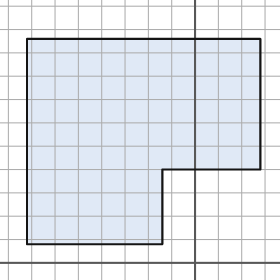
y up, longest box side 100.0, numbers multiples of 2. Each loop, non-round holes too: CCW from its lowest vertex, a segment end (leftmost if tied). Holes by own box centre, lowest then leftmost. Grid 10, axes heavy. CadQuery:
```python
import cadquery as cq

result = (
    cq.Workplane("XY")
    .moveTo(-72.0, 8.0)
    .lineTo(-14.0, 8.0)
    .lineTo(-14.0, 40.0)
    .lineTo(28.0, 40.0)
    .lineTo(28.0, 96.0)
    .lineTo(-72.0, 96.0)
    .close()
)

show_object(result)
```